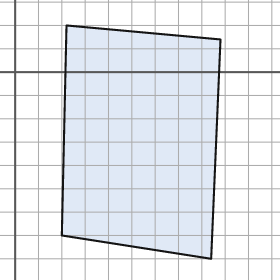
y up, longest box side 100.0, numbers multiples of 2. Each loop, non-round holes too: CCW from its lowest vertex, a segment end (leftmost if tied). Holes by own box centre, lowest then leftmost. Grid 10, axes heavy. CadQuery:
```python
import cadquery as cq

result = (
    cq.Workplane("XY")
    .moveTo(84.0, -80.0)
    .lineTo(88.0, 14.0)
    .lineTo(22.0, 20.0)
    .lineTo(20.0, -70.0)
    .close()
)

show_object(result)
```